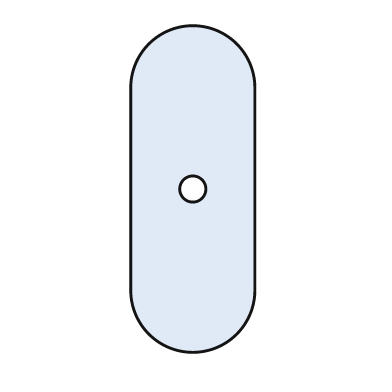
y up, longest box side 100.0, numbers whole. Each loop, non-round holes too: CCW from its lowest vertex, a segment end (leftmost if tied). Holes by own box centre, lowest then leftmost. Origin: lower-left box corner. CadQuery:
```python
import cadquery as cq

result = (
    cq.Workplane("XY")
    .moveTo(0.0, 19.0)
    .threePointArc((19.0, 0.0), (38.0, 19.0))
    .lineTo(38.0, 81.0)
    .threePointArc((19.0, 100.0), (0.0, 81.0))
    .close()
    .moveTo(19.0, 50.0)
    .circle(4.0)
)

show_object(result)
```